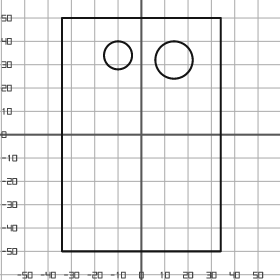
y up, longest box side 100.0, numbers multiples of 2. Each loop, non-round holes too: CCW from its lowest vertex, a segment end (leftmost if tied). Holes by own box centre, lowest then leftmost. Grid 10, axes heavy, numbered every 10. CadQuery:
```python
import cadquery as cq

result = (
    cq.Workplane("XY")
    .moveTo(-34.0, -50.0)
    .lineTo(34.0, -50.0)
    .lineTo(34.0, 50.0)
    .lineTo(-34.0, 50.0)
    .close()
    .moveTo(14.0, 32.0)
    .circle(8.0)
    .moveTo(-10.0, 34.0)
    .circle(6.0)
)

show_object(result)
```